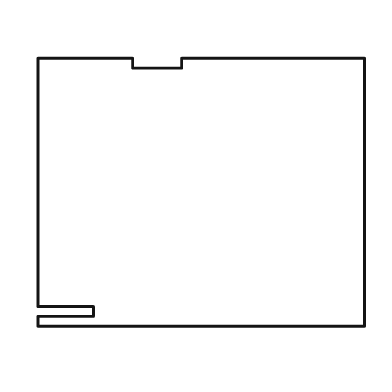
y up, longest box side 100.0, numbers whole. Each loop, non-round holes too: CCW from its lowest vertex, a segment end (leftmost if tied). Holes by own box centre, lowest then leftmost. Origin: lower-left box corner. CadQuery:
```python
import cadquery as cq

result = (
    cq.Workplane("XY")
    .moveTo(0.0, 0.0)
    .lineTo(100.0, 0.0)
    .lineTo(100.0, 82.0)
    .lineTo(44.0, 82.0)
    .lineTo(44.0, 79.0)
    .lineTo(29.0, 79.0)
    .lineTo(29.0, 82.0)
    .lineTo(0.0, 82.0)
    .lineTo(0.0, 6.0)
    .lineTo(17.0, 6.0)
    .lineTo(17.0, 3.0)
    .lineTo(0.0, 3.0)
    .close()
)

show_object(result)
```